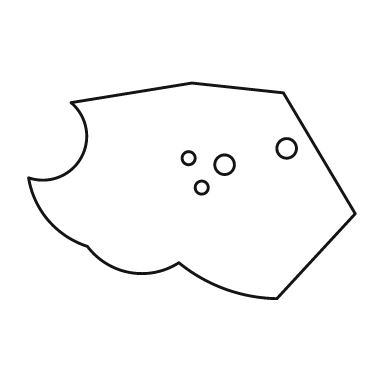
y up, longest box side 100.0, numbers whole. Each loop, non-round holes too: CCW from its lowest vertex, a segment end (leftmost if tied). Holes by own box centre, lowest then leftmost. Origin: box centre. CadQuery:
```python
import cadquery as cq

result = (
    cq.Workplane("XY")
    .moveTo(26.0, -33.0)
    .lineTo(50.0, -7.0)
    .lineTo(28.0, 30.0)
    .lineTo(0.0, 33.0)
    .lineTo(-37.0, 27.0)
    .threePointArc((-34.0, 10.0), (-50.0, 4.0))
    .threePointArc((-44.0, -9.0), (-32.0, -17.0))
    .threePointArc((-19.0, -25.0), (-4.0, -22.0))
    .threePointArc((10.0, -30.0), (26.0, -33.0))
    .close()
    .moveTo(3.0, 1.0)
    .circle(2.0)
    .moveTo(10.0, 8.0)
    .circle(3.0)
    .moveTo(-1.0, 10.0)
    .circle(2.0)
    .moveTo(29.0, 13.0)
    .circle(3.0)
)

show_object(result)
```